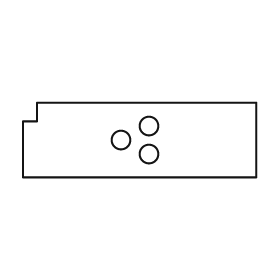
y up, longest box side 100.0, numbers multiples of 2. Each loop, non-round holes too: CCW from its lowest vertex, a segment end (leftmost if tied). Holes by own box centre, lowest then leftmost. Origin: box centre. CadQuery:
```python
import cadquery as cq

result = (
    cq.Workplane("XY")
    .moveTo(-50.0, -16.0)
    .lineTo(50.0, -16.0)
    .lineTo(50.0, 16.0)
    .lineTo(-44.0, 16.0)
    .lineTo(-44.0, 8.0)
    .lineTo(-50.0, 8.0)
    .close()
    .moveTo(4.0, -6.0)
    .circle(4.0)
    .moveTo(-8.0, 0.0)
    .circle(4.0)
    .moveTo(4.0, 6.0)
    .circle(4.0)
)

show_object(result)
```